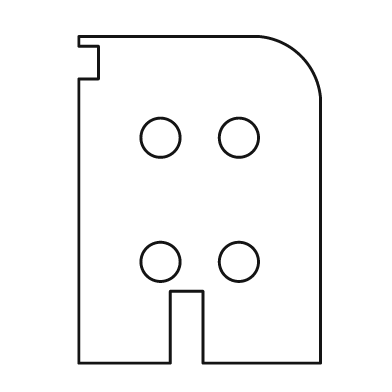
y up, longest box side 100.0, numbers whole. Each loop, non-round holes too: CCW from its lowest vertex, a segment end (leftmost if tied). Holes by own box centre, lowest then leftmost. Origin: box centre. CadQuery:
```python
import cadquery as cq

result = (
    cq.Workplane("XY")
    .moveTo(-37.0, -50.0)
    .lineTo(-9.0, -50.0)
    .lineTo(-9.0, -28.0)
    .lineTo(1.0, -28.0)
    .lineTo(1.0, -50.0)
    .lineTo(37.0, -50.0)
    .lineTo(37.0, 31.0)
    .threePointArc((31.0, 44.0), (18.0, 50.0))
    .lineTo(-37.0, 50.0)
    .lineTo(-37.0, 47.0)
    .lineTo(-31.0, 47.0)
    .lineTo(-31.0, 37.0)
    .lineTo(-37.0, 37.0)
    .close()
    .moveTo(-12.0, -19.0)
    .circle(6.0)
    .moveTo(12.0, -19.0)
    .circle(6.0)
    .moveTo(-12.0, 19.0)
    .circle(6.0)
    .moveTo(12.0, 19.0)
    .circle(6.0)
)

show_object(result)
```